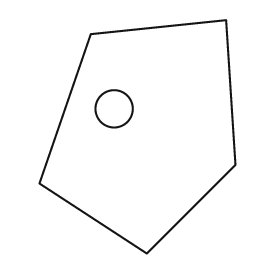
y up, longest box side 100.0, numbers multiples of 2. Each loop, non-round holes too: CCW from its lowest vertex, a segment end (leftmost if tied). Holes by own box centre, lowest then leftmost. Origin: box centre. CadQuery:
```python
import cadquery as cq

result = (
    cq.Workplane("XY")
    .moveTo(4.0, -50.0)
    .lineTo(42.0, -12.0)
    .lineTo(38.0, 50.0)
    .lineTo(-20.0, 44.0)
    .lineTo(-42.0, -20.0)
    .close()
    .moveTo(-10.0, 12.0)
    .circle(8.0)
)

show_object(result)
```